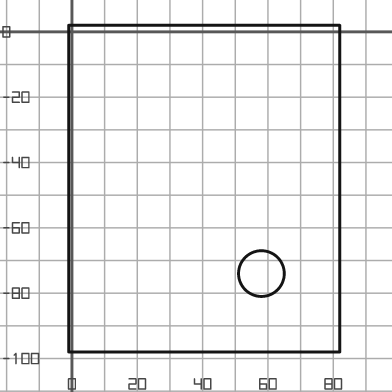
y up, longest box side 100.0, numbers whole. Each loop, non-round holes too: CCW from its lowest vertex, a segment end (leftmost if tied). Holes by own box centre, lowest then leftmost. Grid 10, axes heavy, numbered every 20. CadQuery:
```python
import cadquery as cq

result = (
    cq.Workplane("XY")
    .moveTo(-1.0, -98.0)
    .lineTo(82.0, -98.0)
    .lineTo(82.0, 2.0)
    .lineTo(-1.0, 2.0)
    .close()
    .moveTo(58.0, -74.0)
    .circle(7.0)
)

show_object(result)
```